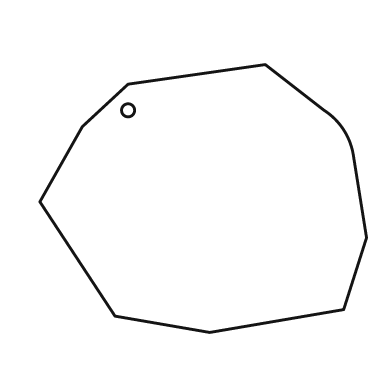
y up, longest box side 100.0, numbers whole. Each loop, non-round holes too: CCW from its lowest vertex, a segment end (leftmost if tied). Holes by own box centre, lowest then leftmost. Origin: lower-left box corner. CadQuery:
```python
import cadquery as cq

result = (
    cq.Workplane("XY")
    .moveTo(52.0, 0.0)
    .lineTo(93.0, 7.0)
    .lineTo(100.0, 29.0)
    .lineTo(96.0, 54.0)
    .threePointArc((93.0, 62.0), (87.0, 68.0))
    .lineTo(69.0, 82.0)
    .lineTo(27.0, 76.0)
    .lineTo(13.0, 63.0)
    .lineTo(0.0, 40.0)
    .lineTo(23.0, 5.0)
    .close()
    .moveTo(27.0, 68.0)
    .circle(2.0)
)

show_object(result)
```